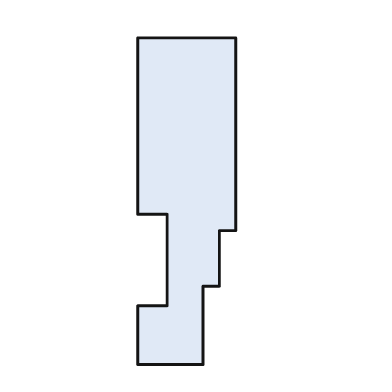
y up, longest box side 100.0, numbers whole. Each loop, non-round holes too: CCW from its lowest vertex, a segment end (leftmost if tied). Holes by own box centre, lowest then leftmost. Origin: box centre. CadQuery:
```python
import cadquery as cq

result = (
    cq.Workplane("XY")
    .moveTo(-15.0, -50.0)
    .lineTo(5.0, -50.0)
    .lineTo(5.0, -26.0)
    .lineTo(10.0, -26.0)
    .lineTo(10.0, -9.0)
    .lineTo(15.0, -9.0)
    .lineTo(15.0, 50.0)
    .lineTo(-15.0, 50.0)
    .lineTo(-15.0, -4.0)
    .lineTo(-6.0, -4.0)
    .lineTo(-6.0, -32.0)
    .lineTo(-15.0, -32.0)
    .close()
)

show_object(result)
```